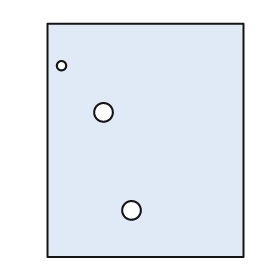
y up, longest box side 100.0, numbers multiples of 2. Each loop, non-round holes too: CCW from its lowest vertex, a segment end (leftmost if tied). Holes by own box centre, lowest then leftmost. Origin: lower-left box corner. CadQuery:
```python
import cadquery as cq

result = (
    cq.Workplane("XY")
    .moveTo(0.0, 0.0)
    .lineTo(84.0, 0.0)
    .lineTo(84.0, 100.0)
    .lineTo(0.0, 100.0)
    .close()
    .moveTo(36.0, 20.0)
    .circle(4.0)
    .moveTo(24.0, 62.0)
    .circle(4.0)
    .moveTo(6.0, 82.0)
    .circle(2.0)
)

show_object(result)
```